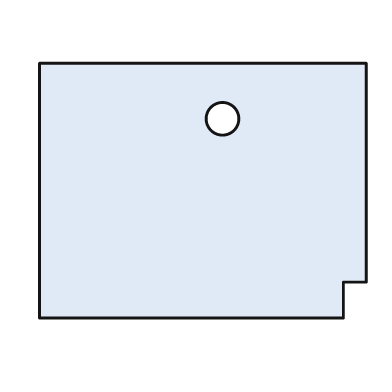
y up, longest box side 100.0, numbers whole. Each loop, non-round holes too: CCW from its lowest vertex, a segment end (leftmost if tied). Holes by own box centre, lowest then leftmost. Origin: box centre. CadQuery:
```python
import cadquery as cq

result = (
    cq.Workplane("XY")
    .moveTo(-50.0, -39.0)
    .lineTo(43.0, -39.0)
    .lineTo(43.0, -28.0)
    .lineTo(50.0, -28.0)
    .lineTo(50.0, 39.0)
    .lineTo(-50.0, 39.0)
    .close()
    .moveTo(6.0, 22.0)
    .circle(5.0)
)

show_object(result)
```